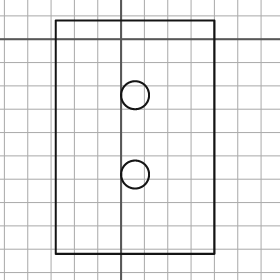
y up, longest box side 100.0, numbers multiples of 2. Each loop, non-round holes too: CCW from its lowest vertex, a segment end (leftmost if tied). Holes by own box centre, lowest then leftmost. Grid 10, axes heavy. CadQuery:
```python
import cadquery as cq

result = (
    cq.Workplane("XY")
    .moveTo(-28.0, -92.0)
    .lineTo(40.0, -92.0)
    .lineTo(40.0, 8.0)
    .lineTo(-28.0, 8.0)
    .close()
    .moveTo(6.0, -58.0)
    .circle(6.0)
    .moveTo(6.0, -24.0)
    .circle(6.0)
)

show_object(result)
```